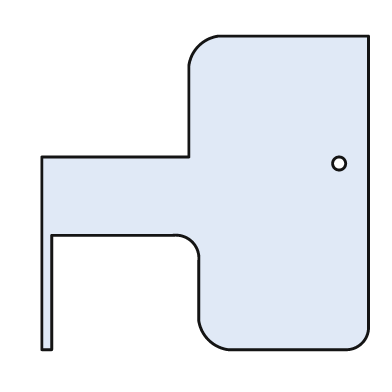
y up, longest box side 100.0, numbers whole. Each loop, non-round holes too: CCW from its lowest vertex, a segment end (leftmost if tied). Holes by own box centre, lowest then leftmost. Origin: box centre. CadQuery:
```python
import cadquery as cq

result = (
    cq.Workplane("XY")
    .moveTo(-50.0, -48.0)
    .lineTo(-47.0, -48.0)
    .lineTo(-47.0, -13.0)
    .lineTo(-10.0, -13.0)
    .threePointArc((-4.0, -15.0), (-2.0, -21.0))
    .lineTo(-2.0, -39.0)
    .threePointArc((1.0, -45.0), (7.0, -48.0))
    .lineTo(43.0, -48.0)
    .threePointArc((48.0, -46.0), (50.0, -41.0))
    .lineTo(50.0, 48.0)
    .lineTo(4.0, 48.0)
    .threePointArc((-2.0, 45.0), (-5.0, 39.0))
    .lineTo(-5.0, 11.0)
    .lineTo(-50.0, 11.0)
    .close()
    .moveTo(41.0, 9.0)
    .circle(2.0)
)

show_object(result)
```